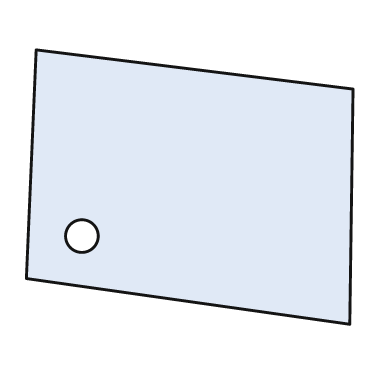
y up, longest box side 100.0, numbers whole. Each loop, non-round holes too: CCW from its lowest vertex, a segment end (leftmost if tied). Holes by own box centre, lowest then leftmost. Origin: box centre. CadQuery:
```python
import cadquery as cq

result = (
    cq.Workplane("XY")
    .moveTo(49.0, -42.0)
    .lineTo(50.0, 30.0)
    .lineTo(-47.0, 42.0)
    .lineTo(-50.0, -28.0)
    .close()
    .moveTo(-33.0, -15.0)
    .circle(5.0)
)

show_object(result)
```